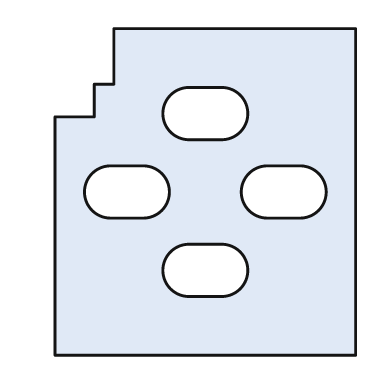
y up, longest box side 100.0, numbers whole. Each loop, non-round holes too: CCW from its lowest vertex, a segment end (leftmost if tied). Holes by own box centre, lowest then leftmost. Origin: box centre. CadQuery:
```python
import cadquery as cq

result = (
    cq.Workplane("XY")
    .moveTo(-46.0, -50.0)
    .lineTo(46.0, -50.0)
    .lineTo(46.0, 50.0)
    .lineTo(-28.0, 50.0)
    .lineTo(-28.0, 33.0)
    .lineTo(-34.0, 33.0)
    .lineTo(-34.0, 23.0)
    .lineTo(-46.0, 23.0)
    .close()
    .moveTo(-5.0, -32.0)
    .lineTo(5.0, -32.0)
    .threePointArc((13.0, -24.0), (5.0, -16.0))
    .lineTo(-5.0, -16.0)
    .threePointArc((-13.0, -24.0), (-5.0, -32.0))
    .close()
    .moveTo(-29.0, -8.0)
    .lineTo(-19.0, -8.0)
    .threePointArc((-11.0, 0.0), (-19.0, 8.0))
    .lineTo(-29.0, 8.0)
    .threePointArc((-37.0, 0.0), (-29.0, -8.0))
    .close()
    .moveTo(19.0, -8.0)
    .lineTo(29.0, -8.0)
    .threePointArc((37.0, 0.0), (29.0, 8.0))
    .lineTo(19.0, 8.0)
    .threePointArc((11.0, 0.0), (19.0, -8.0))
    .close()
    .moveTo(-5.0, 16.0)
    .lineTo(5.0, 16.0)
    .threePointArc((13.0, 24.0), (5.0, 32.0))
    .lineTo(-5.0, 32.0)
    .threePointArc((-13.0, 24.0), (-5.0, 16.0))
    .close()
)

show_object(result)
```